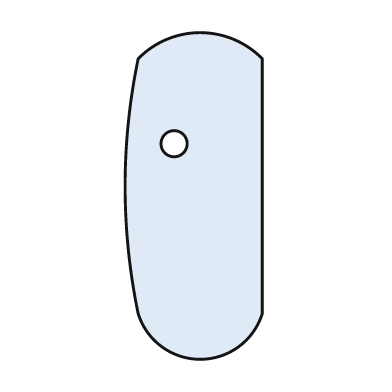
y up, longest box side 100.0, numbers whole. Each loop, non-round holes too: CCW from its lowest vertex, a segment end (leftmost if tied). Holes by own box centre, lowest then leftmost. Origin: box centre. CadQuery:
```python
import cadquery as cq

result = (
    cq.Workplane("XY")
    .moveTo(-17.0, -36.0)
    .threePointArc((2.0, -50.0), (21.0, -36.0))
    .lineTo(21.0, 42.0)
    .threePointArc((2.0, 50.0), (-17.0, 42.0))
    .threePointArc((-21.0, 3.0), (-17.0, -36.0))
    .close()
    .moveTo(-6.0, 16.0)
    .circle(4.0)
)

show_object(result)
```